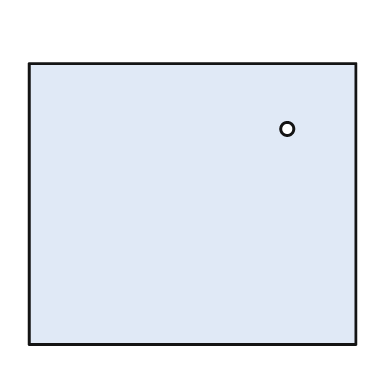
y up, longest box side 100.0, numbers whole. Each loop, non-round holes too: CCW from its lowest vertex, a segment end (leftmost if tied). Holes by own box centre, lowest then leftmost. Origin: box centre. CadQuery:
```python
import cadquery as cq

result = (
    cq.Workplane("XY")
    .moveTo(-50.0, -43.0)
    .lineTo(50.0, -43.0)
    .lineTo(50.0, 43.0)
    .lineTo(-50.0, 43.0)
    .close()
    .moveTo(29.0, 23.0)
    .circle(2.0)
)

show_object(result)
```